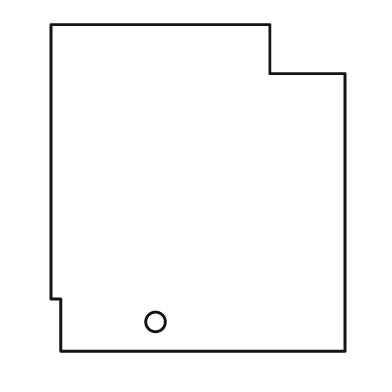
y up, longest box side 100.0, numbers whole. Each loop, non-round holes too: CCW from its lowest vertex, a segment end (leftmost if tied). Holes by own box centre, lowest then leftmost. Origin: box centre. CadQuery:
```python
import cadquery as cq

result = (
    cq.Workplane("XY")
    .moveTo(-42.0, -50.0)
    .lineTo(45.0, -50.0)
    .lineTo(45.0, 35.0)
    .lineTo(22.0, 35.0)
    .lineTo(22.0, 50.0)
    .lineTo(-45.0, 50.0)
    .lineTo(-45.0, -34.0)
    .lineTo(-42.0, -34.0)
    .close()
    .moveTo(-13.0, -41.0)
    .circle(3.0)
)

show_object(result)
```